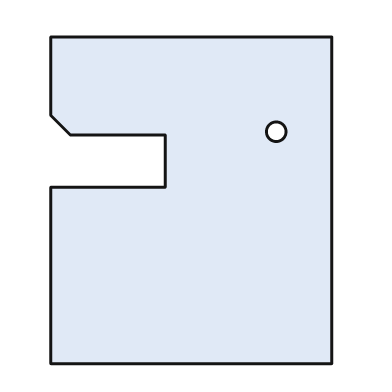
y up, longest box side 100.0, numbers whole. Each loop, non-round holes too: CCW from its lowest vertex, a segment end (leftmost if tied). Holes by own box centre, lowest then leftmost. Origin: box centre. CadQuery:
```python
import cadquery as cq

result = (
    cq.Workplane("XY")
    .moveTo(-43.0, -50.0)
    .lineTo(43.0, -50.0)
    .lineTo(43.0, 50.0)
    .lineTo(-43.0, 50.0)
    .lineTo(-43.0, 26.0)
    .lineTo(-37.0, 20.0)
    .lineTo(-8.0, 20.0)
    .lineTo(-8.0, 4.0)
    .lineTo(-43.0, 4.0)
    .close()
    .moveTo(26.0, 21.0)
    .circle(3.0)
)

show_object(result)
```